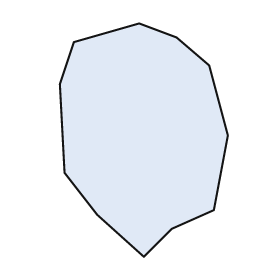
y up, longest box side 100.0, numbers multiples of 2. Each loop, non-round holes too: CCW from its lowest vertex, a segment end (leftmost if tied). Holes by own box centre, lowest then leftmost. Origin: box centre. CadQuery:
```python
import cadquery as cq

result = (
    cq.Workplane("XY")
    .moveTo(0.0, -50.0)
    .lineTo(12.0, -38.0)
    .lineTo(30.0, -30.0)
    .lineTo(36.0, 2.0)
    .lineTo(28.0, 32.0)
    .lineTo(14.0, 44.0)
    .lineTo(-2.0, 50.0)
    .lineTo(-30.0, 42.0)
    .lineTo(-36.0, 24.0)
    .lineTo(-34.0, -14.0)
    .lineTo(-20.0, -32.0)
    .close()
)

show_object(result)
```